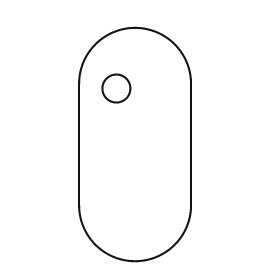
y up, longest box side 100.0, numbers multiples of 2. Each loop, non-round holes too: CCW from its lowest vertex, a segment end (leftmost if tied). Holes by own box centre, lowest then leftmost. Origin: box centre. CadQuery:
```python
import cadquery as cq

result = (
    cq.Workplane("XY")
    .moveTo(-24.0, -26.0)
    .threePointArc((0.0, -50.0), (24.0, -26.0))
    .lineTo(24.0, 26.0)
    .threePointArc((0.0, 50.0), (-24.0, 26.0))
    .close()
    .moveTo(-8.0, 24.0)
    .circle(6.0)
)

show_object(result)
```